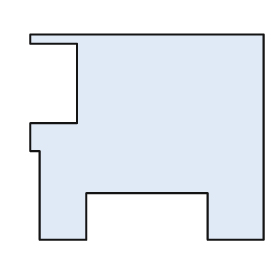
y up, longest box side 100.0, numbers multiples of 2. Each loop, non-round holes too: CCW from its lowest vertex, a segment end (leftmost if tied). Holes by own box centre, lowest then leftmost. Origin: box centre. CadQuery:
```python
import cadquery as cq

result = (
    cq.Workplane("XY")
    .moveTo(-46.0, -44.0)
    .lineTo(-26.0, -44.0)
    .lineTo(-26.0, -24.0)
    .lineTo(26.0, -24.0)
    .lineTo(26.0, -44.0)
    .lineTo(50.0, -44.0)
    .lineTo(50.0, 44.0)
    .lineTo(-50.0, 44.0)
    .lineTo(-50.0, 40.0)
    .lineTo(-30.0, 40.0)
    .lineTo(-30.0, 6.0)
    .lineTo(-50.0, 6.0)
    .lineTo(-50.0, -6.0)
    .lineTo(-46.0, -6.0)
    .close()
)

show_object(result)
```